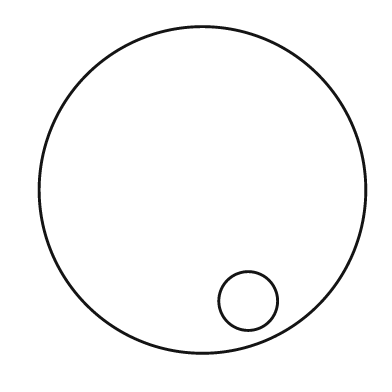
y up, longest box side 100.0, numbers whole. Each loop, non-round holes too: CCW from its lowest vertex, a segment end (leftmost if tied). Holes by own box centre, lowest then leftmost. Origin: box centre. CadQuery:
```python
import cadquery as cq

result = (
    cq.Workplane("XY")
    .moveTo(0.0, 0.0)
    .circle(50.0)
    .moveTo(14.0, -34.0)
    .circle(9.0)
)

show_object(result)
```